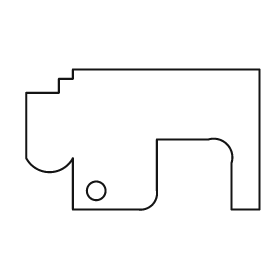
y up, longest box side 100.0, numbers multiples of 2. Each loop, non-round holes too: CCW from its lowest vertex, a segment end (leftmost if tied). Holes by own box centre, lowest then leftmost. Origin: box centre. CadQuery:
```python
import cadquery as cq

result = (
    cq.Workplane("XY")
    .moveTo(-30.0, -30.0)
    .lineTo(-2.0, -30.0)
    .threePointArc((4.0, -28.0), (6.0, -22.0))
    .lineTo(6.0, 0.0)
    .lineTo(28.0, 0.0)
    .threePointArc((36.0, -2.0), (38.0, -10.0))
    .lineTo(38.0, -30.0)
    .lineTo(50.0, -30.0)
    .lineTo(50.0, 30.0)
    .lineTo(-30.0, 30.0)
    .lineTo(-30.0, 26.0)
    .lineTo(-36.0, 26.0)
    .lineTo(-36.0, 20.0)
    .lineTo(-50.0, 20.0)
    .lineTo(-50.0, -8.0)
    .threePointArc((-40.0, -14.0), (-30.0, -8.0))
    .close()
    .moveTo(-20.0, -22.0)
    .circle(4.0)
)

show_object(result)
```